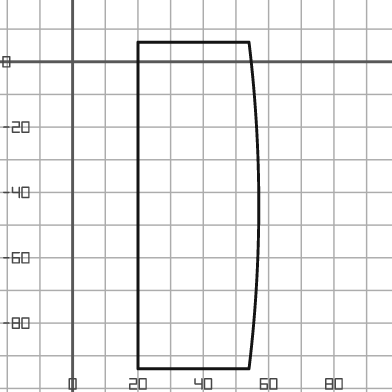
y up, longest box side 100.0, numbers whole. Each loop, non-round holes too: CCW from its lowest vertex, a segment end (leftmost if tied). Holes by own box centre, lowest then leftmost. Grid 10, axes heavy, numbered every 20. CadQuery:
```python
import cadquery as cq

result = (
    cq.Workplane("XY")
    .moveTo(20.0, -94.0)
    .lineTo(54.0, -94.0)
    .threePointArc((57.0, -44.0), (54.0, 6.0))
    .lineTo(20.0, 6.0)
    .close()
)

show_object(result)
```